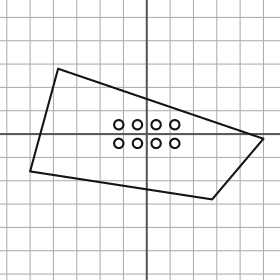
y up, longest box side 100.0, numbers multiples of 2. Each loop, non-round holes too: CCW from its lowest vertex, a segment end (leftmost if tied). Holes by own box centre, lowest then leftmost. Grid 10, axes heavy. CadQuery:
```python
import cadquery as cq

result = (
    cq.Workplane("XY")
    .moveTo(28.0, -28.0)
    .lineTo(50.0, -2.0)
    .lineTo(-38.0, 28.0)
    .lineTo(-50.0, -16.0)
    .close()
    .moveTo(-12.0, -4.0)
    .circle(2.0)
    .moveTo(-4.0, -4.0)
    .circle(2.0)
    .moveTo(4.0, -4.0)
    .circle(2.0)
    .moveTo(12.0, -4.0)
    .circle(2.0)
    .moveTo(-12.0, 4.0)
    .circle(2.0)
    .moveTo(-4.0, 4.0)
    .circle(2.0)
    .moveTo(4.0, 4.0)
    .circle(2.0)
    .moveTo(12.0, 4.0)
    .circle(2.0)
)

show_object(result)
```